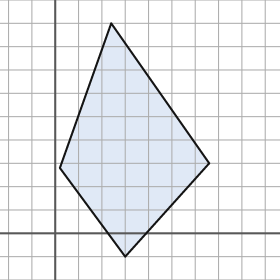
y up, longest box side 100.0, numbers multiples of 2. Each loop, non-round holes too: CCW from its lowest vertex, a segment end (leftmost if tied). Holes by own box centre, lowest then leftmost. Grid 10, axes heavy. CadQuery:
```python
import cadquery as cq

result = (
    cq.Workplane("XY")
    .moveTo(30.0, -10.0)
    .lineTo(66.0, 30.0)
    .lineTo(24.0, 90.0)
    .lineTo(2.0, 28.0)
    .close()
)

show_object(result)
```